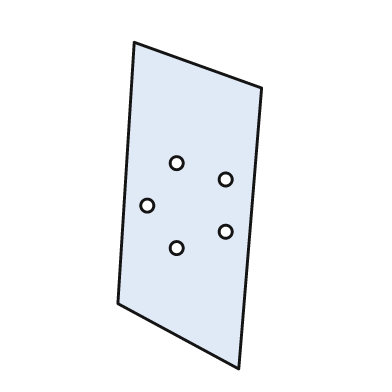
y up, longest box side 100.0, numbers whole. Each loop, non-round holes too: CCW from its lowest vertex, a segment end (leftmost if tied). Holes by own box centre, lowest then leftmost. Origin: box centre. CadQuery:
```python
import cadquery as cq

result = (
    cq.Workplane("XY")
    .moveTo(15.0, -50.0)
    .lineTo(22.0, 36.0)
    .lineTo(-17.0, 50.0)
    .lineTo(-22.0, -30.0)
    .close()
    .moveTo(-4.0, -13.0)
    .circle(2.0)
    .moveTo(11.0, -8.0)
    .circle(2.0)
    .moveTo(-13.0, 0.0)
    .circle(2.0)
    .moveTo(11.0, 8.0)
    .circle(2.0)
    .moveTo(-4.0, 13.0)
    .circle(2.0)
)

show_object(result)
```